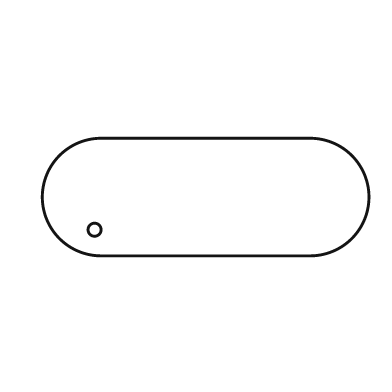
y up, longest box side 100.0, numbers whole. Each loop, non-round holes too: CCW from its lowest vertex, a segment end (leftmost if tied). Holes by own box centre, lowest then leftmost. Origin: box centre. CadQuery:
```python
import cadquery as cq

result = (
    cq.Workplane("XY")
    .moveTo(-32.0, -18.0)
    .lineTo(32.0, -18.0)
    .threePointArc((50.0, 0.0), (32.0, 18.0))
    .lineTo(-32.0, 18.0)
    .threePointArc((-50.0, 0.0), (-32.0, -18.0))
    .close()
    .moveTo(-34.0, -10.0)
    .circle(2.0)
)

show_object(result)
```